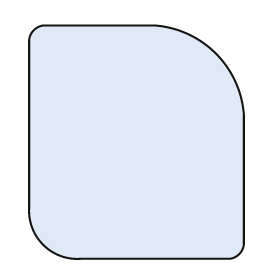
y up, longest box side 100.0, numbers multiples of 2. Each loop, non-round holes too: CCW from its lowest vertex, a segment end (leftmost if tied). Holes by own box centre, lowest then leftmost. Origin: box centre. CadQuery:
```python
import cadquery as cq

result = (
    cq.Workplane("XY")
    .moveTo(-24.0, -50.0)
    .lineTo(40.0, -50.0)
    .threePointArc((44.0, -48.0), (46.0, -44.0))
    .lineTo(46.0, 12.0)
    .threePointArc((34.0, 38.0), (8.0, 50.0))
    .lineTo(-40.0, 50.0)
    .threePointArc((-44.0, 48.0), (-46.0, 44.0))
    .lineTo(-46.0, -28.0)
    .threePointArc((-40.0, -44.0), (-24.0, -50.0))
    .close()
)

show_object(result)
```